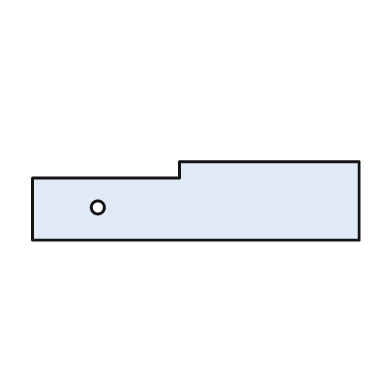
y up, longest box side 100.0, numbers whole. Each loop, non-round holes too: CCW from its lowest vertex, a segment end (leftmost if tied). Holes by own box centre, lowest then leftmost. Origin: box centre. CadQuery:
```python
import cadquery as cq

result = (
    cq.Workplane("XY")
    .moveTo(-50.0, -12.0)
    .lineTo(50.0, -12.0)
    .lineTo(50.0, 12.0)
    .lineTo(-5.0, 12.0)
    .lineTo(-5.0, 7.0)
    .lineTo(-50.0, 7.0)
    .close()
    .moveTo(-30.0, -2.0)
    .circle(2.0)
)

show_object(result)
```